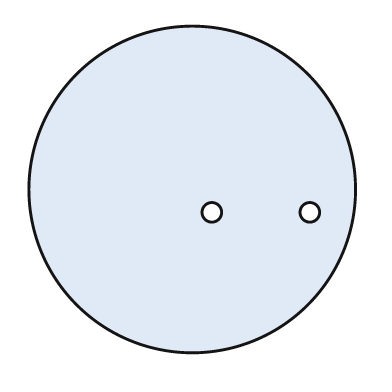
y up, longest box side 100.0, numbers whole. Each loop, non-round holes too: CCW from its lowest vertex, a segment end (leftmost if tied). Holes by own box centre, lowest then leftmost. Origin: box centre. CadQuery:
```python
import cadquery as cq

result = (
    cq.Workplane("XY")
    .moveTo(0.0, 0.0)
    .circle(50.0)
    .moveTo(6.0, -7.0)
    .circle(3.0)
    .moveTo(36.0, -7.0)
    .circle(3.0)
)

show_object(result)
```